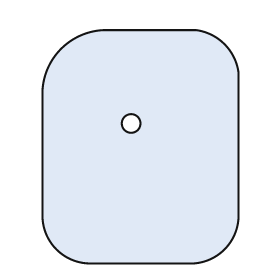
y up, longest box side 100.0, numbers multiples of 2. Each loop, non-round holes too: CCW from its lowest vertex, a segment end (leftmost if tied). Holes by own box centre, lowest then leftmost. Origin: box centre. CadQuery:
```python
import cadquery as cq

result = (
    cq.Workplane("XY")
    .moveTo(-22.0, -50.0)
    .lineTo(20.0, -50.0)
    .threePointArc((36.0, -44.0), (42.0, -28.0))
    .lineTo(42.0, 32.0)
    .threePointArc((36.0, 44.0), (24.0, 50.0))
    .lineTo(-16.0, 50.0)
    .threePointArc((-34.0, 42.0), (-42.0, 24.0))
    .lineTo(-42.0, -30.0)
    .threePointArc((-36.0, -44.0), (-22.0, -50.0))
    .close()
    .moveTo(-4.0, 10.0)
    .circle(4.0)
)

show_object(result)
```